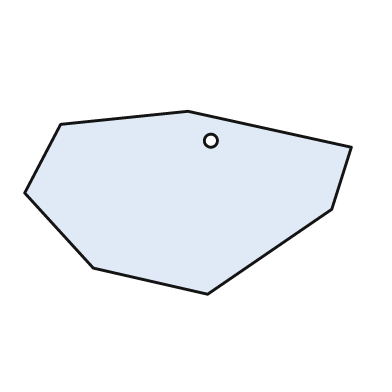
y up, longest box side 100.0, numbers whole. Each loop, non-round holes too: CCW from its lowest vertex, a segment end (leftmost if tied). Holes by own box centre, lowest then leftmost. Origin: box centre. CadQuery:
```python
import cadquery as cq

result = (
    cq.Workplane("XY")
    .moveTo(6.0, -28.0)
    .lineTo(44.0, -2.0)
    .lineTo(50.0, 17.0)
    .lineTo(0.0, 28.0)
    .lineTo(-39.0, 24.0)
    .lineTo(-50.0, 3.0)
    .lineTo(-29.0, -20.0)
    .close()
    .moveTo(7.0, 19.0)
    .circle(2.0)
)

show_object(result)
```